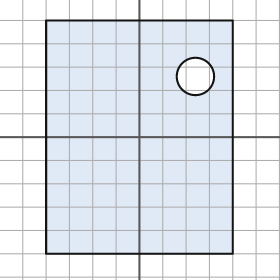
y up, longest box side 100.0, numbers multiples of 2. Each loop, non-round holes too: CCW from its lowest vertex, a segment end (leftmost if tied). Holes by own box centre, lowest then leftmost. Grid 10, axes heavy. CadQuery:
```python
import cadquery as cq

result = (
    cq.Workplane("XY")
    .moveTo(-40.0, -50.0)
    .lineTo(40.0, -50.0)
    .lineTo(40.0, 50.0)
    .lineTo(-40.0, 50.0)
    .close()
    .moveTo(24.0, 26.0)
    .circle(8.0)
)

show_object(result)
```